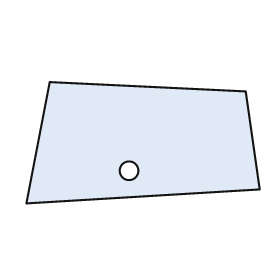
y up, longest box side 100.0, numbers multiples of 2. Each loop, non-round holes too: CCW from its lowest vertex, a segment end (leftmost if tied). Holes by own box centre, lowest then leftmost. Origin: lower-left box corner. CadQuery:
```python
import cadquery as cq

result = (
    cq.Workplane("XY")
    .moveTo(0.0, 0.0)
    .lineTo(100.0, 6.0)
    .lineTo(94.0, 48.0)
    .lineTo(10.0, 52.0)
    .close()
    .moveTo(44.0, 14.0)
    .circle(4.0)
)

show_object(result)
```